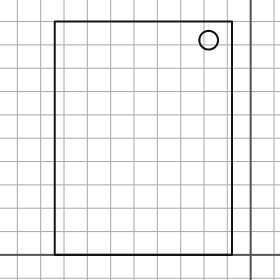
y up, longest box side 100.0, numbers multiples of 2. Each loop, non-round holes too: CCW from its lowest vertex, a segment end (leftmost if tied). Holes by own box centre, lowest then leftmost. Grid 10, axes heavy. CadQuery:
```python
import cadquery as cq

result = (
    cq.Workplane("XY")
    .moveTo(-84.0, 0.0)
    .lineTo(-8.0, 0.0)
    .lineTo(-8.0, 100.0)
    .lineTo(-84.0, 100.0)
    .close()
    .moveTo(-18.0, 92.0)
    .circle(4.0)
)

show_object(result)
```